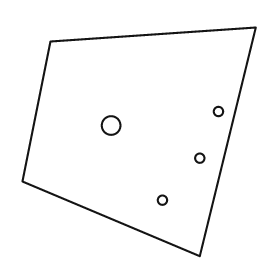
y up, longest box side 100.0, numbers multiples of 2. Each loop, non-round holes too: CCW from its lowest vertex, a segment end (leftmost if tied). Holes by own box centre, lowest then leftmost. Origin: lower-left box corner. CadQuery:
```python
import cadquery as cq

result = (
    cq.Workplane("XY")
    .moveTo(76.0, 0.0)
    .lineTo(100.0, 98.0)
    .lineTo(12.0, 92.0)
    .lineTo(0.0, 32.0)
    .close()
    .moveTo(60.0, 24.0)
    .circle(2.0)
    .moveTo(76.0, 42.0)
    .circle(2.0)
    .moveTo(38.0, 56.0)
    .circle(4.0)
    .moveTo(84.0, 62.0)
    .circle(2.0)
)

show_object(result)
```